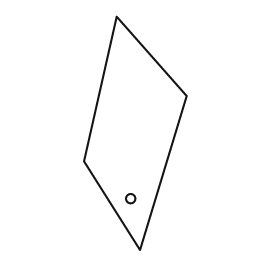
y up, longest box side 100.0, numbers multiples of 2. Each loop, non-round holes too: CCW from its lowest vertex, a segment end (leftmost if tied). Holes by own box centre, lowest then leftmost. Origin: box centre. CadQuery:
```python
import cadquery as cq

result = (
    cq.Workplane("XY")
    .moveTo(2.0, -50.0)
    .lineTo(22.0, 16.0)
    .lineTo(-8.0, 50.0)
    .lineTo(-22.0, -12.0)
    .close()
    .moveTo(-2.0, -28.0)
    .circle(2.0)
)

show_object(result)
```